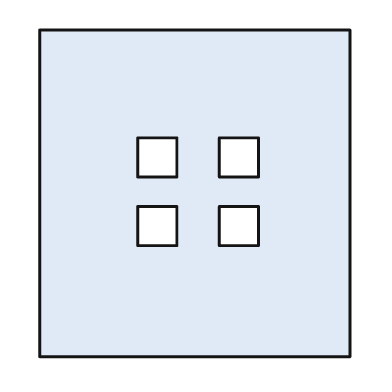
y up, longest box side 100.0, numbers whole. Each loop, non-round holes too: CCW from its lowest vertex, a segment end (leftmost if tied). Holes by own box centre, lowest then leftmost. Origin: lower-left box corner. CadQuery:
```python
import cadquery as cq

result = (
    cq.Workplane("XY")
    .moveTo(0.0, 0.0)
    .lineTo(95.0, 0.0)
    .lineTo(95.0, 100.0)
    .lineTo(0.0, 100.0)
    .close()
    .moveTo(30.0, 34.0)
    .lineTo(42.0, 34.0)
    .lineTo(42.0, 46.0)
    .lineTo(30.0, 46.0)
    .close()
    .moveTo(55.0, 34.0)
    .lineTo(67.0, 34.0)
    .lineTo(67.0, 46.0)
    .lineTo(55.0, 46.0)
    .close()
    .moveTo(30.0, 55.0)
    .lineTo(42.0, 55.0)
    .lineTo(42.0, 67.0)
    .lineTo(30.0, 67.0)
    .close()
    .moveTo(55.0, 55.0)
    .lineTo(67.0, 55.0)
    .lineTo(67.0, 67.0)
    .lineTo(55.0, 67.0)
    .close()
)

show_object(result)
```